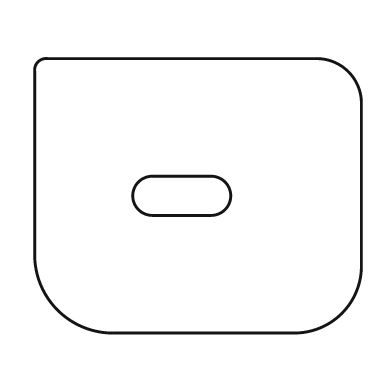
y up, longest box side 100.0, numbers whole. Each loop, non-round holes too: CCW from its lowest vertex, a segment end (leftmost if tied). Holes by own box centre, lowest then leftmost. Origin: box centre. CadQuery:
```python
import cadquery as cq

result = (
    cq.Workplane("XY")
    .moveTo(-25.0, -42.0)
    .lineTo(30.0, -42.0)
    .threePointArc((44.0, -36.0), (50.0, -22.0))
    .lineTo(50.0, 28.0)
    .threePointArc((46.0, 38.0), (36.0, 42.0))
    .lineTo(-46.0, 42.0)
    .threePointArc((-49.0, 41.0), (-50.0, 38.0))
    .lineTo(-50.0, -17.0)
    .threePointArc((-43.0, -35.0), (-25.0, -42.0))
    .close()
    .moveTo(-14.0, -6.0)
    .lineTo(4.0, -6.0)
    .threePointArc((10.0, 0.0), (4.0, 6.0))
    .lineTo(-14.0, 6.0)
    .threePointArc((-20.0, 0.0), (-14.0, -6.0))
    .close()
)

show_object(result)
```